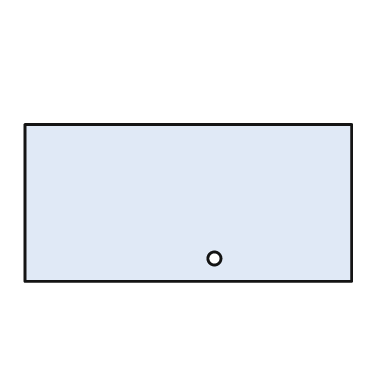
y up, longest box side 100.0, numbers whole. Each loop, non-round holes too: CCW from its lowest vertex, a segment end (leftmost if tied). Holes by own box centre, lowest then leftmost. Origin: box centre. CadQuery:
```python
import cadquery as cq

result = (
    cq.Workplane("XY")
    .moveTo(-50.0, -24.0)
    .lineTo(50.0, -24.0)
    .lineTo(50.0, 24.0)
    .lineTo(-50.0, 24.0)
    .close()
    .moveTo(8.0, -17.0)
    .circle(2.0)
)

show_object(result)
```